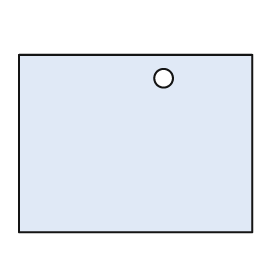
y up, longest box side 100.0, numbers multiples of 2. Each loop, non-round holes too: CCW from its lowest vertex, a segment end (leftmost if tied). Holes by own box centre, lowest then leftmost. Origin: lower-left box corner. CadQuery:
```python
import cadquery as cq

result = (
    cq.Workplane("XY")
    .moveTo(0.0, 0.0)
    .lineTo(100.0, 0.0)
    .lineTo(100.0, 76.0)
    .lineTo(0.0, 76.0)
    .close()
    .moveTo(62.0, 66.0)
    .circle(4.0)
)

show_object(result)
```